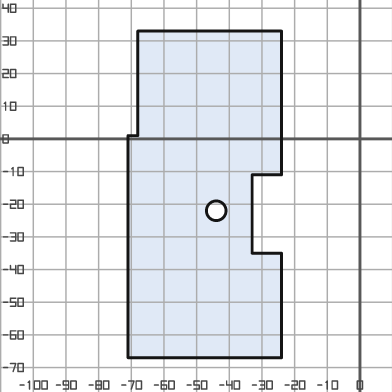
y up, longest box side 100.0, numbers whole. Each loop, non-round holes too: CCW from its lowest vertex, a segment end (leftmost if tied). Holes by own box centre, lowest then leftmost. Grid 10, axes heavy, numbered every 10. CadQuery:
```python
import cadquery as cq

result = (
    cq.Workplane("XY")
    .moveTo(-71.0, -67.0)
    .lineTo(-24.0, -67.0)
    .lineTo(-24.0, -35.0)
    .lineTo(-33.0, -35.0)
    .lineTo(-33.0, -11.0)
    .lineTo(-24.0, -11.0)
    .lineTo(-24.0, 33.0)
    .lineTo(-68.0, 33.0)
    .lineTo(-68.0, 1.0)
    .lineTo(-71.0, 1.0)
    .close()
    .moveTo(-44.0, -22.0)
    .circle(3.0)
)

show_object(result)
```